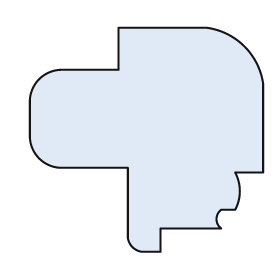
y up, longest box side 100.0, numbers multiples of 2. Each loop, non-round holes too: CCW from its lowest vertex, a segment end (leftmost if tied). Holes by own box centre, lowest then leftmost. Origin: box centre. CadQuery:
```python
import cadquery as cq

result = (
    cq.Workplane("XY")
    .moveTo(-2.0, -48.0)
    .lineTo(6.0, -48.0)
    .lineTo(6.0, -38.0)
    .lineTo(32.0, -38.0)
    .threePointArc((30.0, -34.0), (32.0, -30.0))
    .lineTo(38.0, -30.0)
    .threePointArc((40.0, -22.0), (38.0, -14.0))
    .lineTo(50.0, -14.0)
    .lineTo(50.0, 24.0)
    .threePointArc((42.0, 40.0), (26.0, 48.0))
    .lineTo(-12.0, 48.0)
    .lineTo(-12.0, 30.0)
    .lineTo(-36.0, 30.0)
    .threePointArc((-46.0, 26.0), (-50.0, 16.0))
    .lineTo(-50.0, 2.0)
    .threePointArc((-46.0, -8.0), (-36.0, -12.0))
    .lineTo(-8.0, -12.0)
    .lineTo(-8.0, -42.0)
    .threePointArc((-6.0, -46.0), (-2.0, -48.0))
    .close()
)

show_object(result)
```